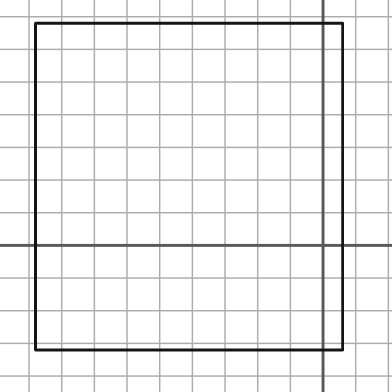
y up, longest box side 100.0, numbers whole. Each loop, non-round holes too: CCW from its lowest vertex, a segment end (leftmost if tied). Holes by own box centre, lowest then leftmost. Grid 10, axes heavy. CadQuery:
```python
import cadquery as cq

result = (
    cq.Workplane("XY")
    .moveTo(-88.0, -32.0)
    .lineTo(6.0, -32.0)
    .lineTo(6.0, 68.0)
    .lineTo(-88.0, 68.0)
    .close()
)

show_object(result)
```